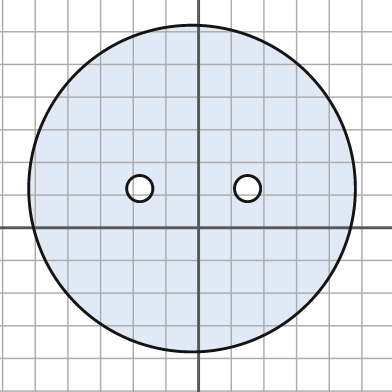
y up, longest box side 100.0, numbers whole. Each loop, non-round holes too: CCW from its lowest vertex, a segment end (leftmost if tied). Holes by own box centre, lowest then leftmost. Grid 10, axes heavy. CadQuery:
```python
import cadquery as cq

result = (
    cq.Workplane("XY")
    .moveTo(-2.0, 12.0)
    .circle(50.0)
    .moveTo(-18.0, 12.0)
    .circle(4.0)
    .moveTo(15.0, 12.0)
    .circle(4.0)
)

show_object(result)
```